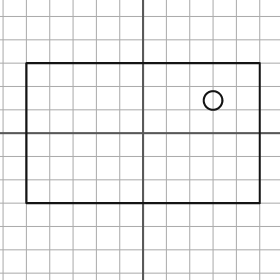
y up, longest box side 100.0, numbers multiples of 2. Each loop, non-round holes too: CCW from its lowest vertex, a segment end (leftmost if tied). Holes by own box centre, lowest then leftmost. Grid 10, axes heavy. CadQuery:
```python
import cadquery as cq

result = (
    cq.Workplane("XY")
    .moveTo(-50.0, -30.0)
    .lineTo(50.0, -30.0)
    .lineTo(50.0, 30.0)
    .lineTo(-50.0, 30.0)
    .close()
    .moveTo(30.0, 14.0)
    .circle(4.0)
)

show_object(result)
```